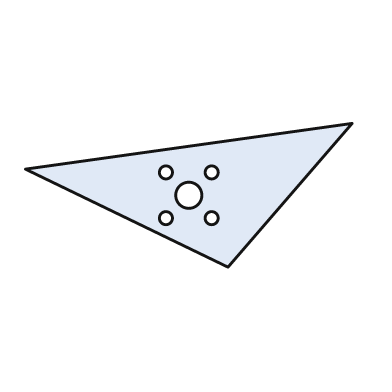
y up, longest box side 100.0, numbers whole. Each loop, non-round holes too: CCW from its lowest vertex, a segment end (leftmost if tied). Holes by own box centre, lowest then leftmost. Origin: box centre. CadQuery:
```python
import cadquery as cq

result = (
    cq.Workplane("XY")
    .moveTo(12.0, -22.0)
    .lineTo(50.0, 22.0)
    .lineTo(-50.0, 8.0)
    .close()
    .moveTo(-7.0, -7.0)
    .circle(2.0)
    .moveTo(7.0, -7.0)
    .circle(2.0)
    .moveTo(0.0, 0.0)
    .circle(4.0)
    .moveTo(-7.0, 7.0)
    .circle(2.0)
    .moveTo(7.0, 7.0)
    .circle(2.0)
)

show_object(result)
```